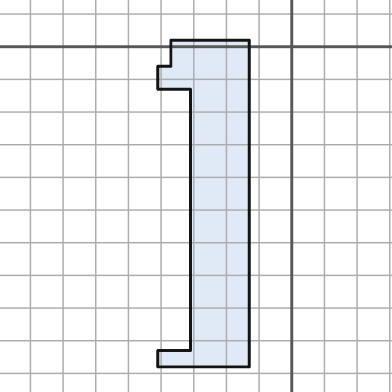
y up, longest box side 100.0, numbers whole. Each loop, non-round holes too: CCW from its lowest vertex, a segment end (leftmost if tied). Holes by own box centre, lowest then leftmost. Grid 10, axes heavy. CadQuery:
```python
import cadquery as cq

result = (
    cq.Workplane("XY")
    .moveTo(-41.0, -98.0)
    .lineTo(-13.0, -98.0)
    .lineTo(-13.0, 2.0)
    .lineTo(-37.0, 2.0)
    .lineTo(-37.0, -6.0)
    .lineTo(-41.0, -6.0)
    .lineTo(-41.0, -13.0)
    .lineTo(-31.0, -13.0)
    .lineTo(-31.0, -93.0)
    .lineTo(-41.0, -93.0)
    .close()
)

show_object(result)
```